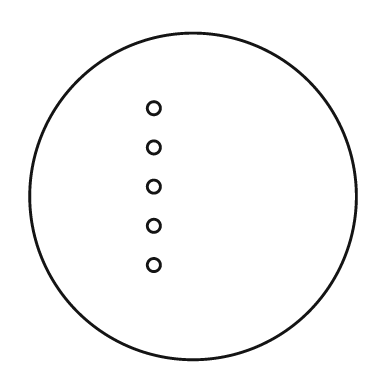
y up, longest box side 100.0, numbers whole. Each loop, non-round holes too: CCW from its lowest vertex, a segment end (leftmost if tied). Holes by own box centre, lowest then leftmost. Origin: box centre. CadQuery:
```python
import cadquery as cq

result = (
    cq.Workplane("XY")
    .moveTo(0.0, 0.0)
    .circle(50.0)
    .moveTo(-12.0, -21.0)
    .circle(2.0)
    .moveTo(-12.0, -9.0)
    .circle(2.0)
    .moveTo(-12.0, 3.0)
    .circle(2.0)
    .moveTo(-12.0, 15.0)
    .circle(2.0)
    .moveTo(-12.0, 27.0)
    .circle(2.0)
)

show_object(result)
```